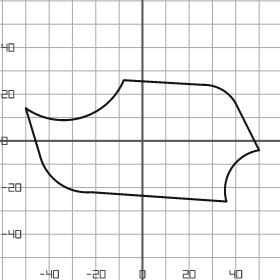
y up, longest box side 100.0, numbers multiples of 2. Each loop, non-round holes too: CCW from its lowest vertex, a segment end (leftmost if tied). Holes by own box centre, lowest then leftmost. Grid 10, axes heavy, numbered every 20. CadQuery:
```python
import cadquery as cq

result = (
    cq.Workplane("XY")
    .moveTo(36.0, -26.0)
    .threePointArc((38.0, -12.0), (50.0, -4.0))
    .lineTo(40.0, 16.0)
    .threePointArc((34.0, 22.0), (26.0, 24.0))
    .lineTo(-8.0, 26.0)
    .threePointArc((-26.0, 10.0), (-50.0, 14.0))
    .lineTo(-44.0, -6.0)
    .threePointArc((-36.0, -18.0), (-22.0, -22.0))
    .close()
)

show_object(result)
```